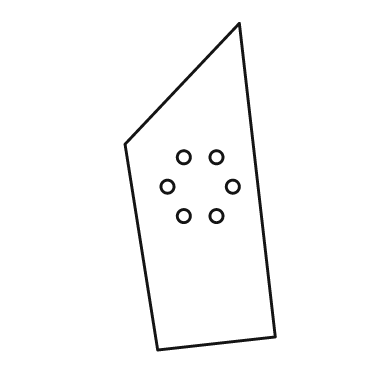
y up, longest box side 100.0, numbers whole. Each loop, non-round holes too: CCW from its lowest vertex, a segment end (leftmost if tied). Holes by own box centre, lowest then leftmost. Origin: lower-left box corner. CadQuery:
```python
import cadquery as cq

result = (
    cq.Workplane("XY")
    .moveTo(10.0, 0.0)
    .lineTo(46.0, 4.0)
    .lineTo(35.0, 100.0)
    .lineTo(0.0, 63.0)
    .close()
    .moveTo(18.0, 41.0)
    .circle(2.0)
    .moveTo(28.0, 41.0)
    .circle(2.0)
    .moveTo(13.0, 50.0)
    .circle(2.0)
    .moveTo(33.0, 50.0)
    .circle(2.0)
    .moveTo(18.0, 59.0)
    .circle(2.0)
    .moveTo(28.0, 59.0)
    .circle(2.0)
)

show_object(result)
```